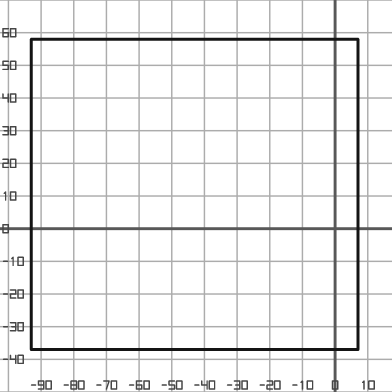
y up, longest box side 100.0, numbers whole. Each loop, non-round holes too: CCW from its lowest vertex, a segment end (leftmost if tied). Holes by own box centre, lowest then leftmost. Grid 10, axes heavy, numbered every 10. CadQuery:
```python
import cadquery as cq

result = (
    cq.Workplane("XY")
    .moveTo(-93.0, -37.0)
    .lineTo(7.0, -37.0)
    .lineTo(7.0, 58.0)
    .lineTo(-93.0, 58.0)
    .close()
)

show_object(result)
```